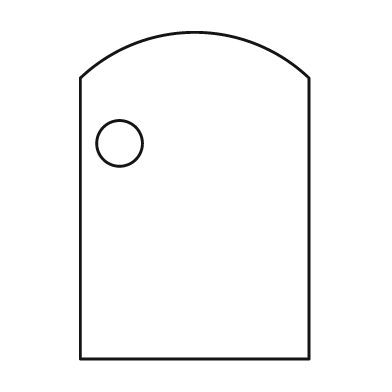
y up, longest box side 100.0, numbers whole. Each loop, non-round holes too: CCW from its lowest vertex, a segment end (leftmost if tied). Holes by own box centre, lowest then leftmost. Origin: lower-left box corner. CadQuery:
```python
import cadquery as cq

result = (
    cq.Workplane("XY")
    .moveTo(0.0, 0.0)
    .lineTo(70.0, 0.0)
    .lineTo(70.0, 86.0)
    .threePointArc((35.0, 100.0), (0.0, 86.0))
    .close()
    .moveTo(12.0, 66.0)
    .circle(7.0)
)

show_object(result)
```